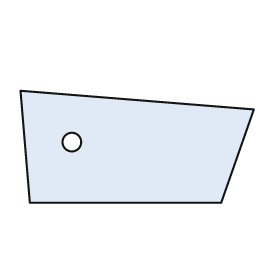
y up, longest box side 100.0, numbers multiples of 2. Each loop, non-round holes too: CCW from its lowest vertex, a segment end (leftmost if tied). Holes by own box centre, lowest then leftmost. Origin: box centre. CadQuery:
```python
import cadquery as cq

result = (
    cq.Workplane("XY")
    .moveTo(-46.0, -24.0)
    .lineTo(36.0, -24.0)
    .lineTo(50.0, 16.0)
    .lineTo(-50.0, 24.0)
    .close()
    .moveTo(-28.0, 2.0)
    .circle(4.0)
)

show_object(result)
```